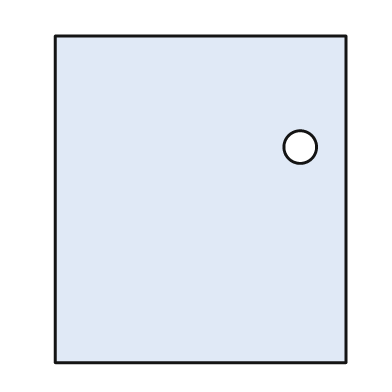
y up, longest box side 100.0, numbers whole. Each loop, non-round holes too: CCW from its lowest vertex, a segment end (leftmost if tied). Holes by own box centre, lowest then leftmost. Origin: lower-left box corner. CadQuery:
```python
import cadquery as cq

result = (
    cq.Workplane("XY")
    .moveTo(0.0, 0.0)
    .lineTo(89.0, 0.0)
    .lineTo(89.0, 100.0)
    .lineTo(0.0, 100.0)
    .close()
    .moveTo(75.0, 66.0)
    .circle(5.0)
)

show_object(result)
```